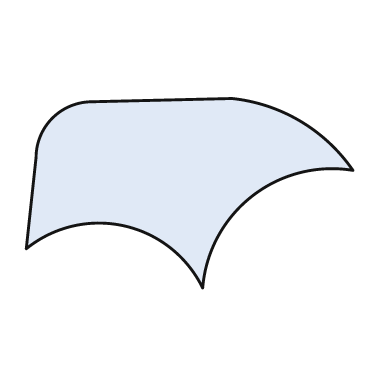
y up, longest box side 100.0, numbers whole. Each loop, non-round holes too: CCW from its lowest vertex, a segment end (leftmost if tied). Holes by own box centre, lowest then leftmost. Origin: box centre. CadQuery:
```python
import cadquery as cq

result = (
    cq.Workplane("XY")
    .moveTo(4.0, -29.0)
    .threePointArc((19.0, -1.0), (50.0, 7.0))
    .threePointArc((34.0, 22.0), (13.0, 29.0))
    .lineTo(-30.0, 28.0)
    .threePointArc((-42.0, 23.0), (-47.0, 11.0))
    .lineTo(-50.0, -17.0)
    .threePointArc((-20.0, -10.0), (4.0, -29.0))
    .close()
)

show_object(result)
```